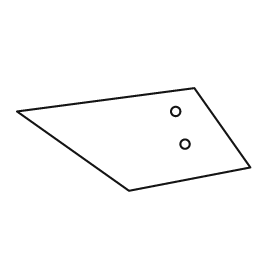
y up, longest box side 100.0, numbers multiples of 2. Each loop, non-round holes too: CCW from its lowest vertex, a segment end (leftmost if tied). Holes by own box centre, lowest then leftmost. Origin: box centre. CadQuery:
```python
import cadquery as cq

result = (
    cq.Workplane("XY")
    .moveTo(-2.0, -22.0)
    .lineTo(50.0, -12.0)
    .lineTo(26.0, 22.0)
    .lineTo(-50.0, 12.0)
    .close()
    .moveTo(22.0, -2.0)
    .circle(2.0)
    .moveTo(18.0, 12.0)
    .circle(2.0)
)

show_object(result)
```